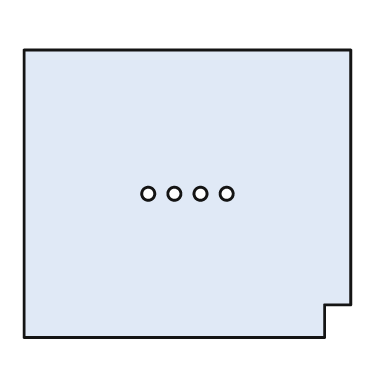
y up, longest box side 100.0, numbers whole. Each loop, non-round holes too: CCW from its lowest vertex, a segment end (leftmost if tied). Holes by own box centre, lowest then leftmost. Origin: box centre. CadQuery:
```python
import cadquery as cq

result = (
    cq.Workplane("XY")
    .moveTo(-50.0, -44.0)
    .lineTo(42.0, -44.0)
    .lineTo(42.0, -34.0)
    .lineTo(50.0, -34.0)
    .lineTo(50.0, 44.0)
    .lineTo(-50.0, 44.0)
    .close()
    .moveTo(-12.0, 0.0)
    .circle(2.0)
    .moveTo(-4.0, 0.0)
    .circle(2.0)
    .moveTo(4.0, 0.0)
    .circle(2.0)
    .moveTo(12.0, 0.0)
    .circle(2.0)
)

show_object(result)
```